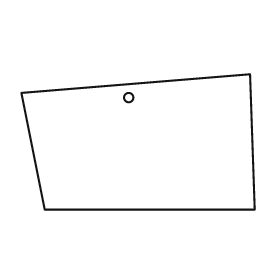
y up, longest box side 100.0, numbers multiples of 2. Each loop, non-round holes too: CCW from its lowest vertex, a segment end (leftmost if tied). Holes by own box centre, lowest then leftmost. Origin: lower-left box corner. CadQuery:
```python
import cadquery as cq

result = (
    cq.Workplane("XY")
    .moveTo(10.0, 0.0)
    .lineTo(100.0, 0.0)
    .lineTo(98.0, 58.0)
    .lineTo(0.0, 50.0)
    .close()
    .moveTo(46.0, 48.0)
    .circle(2.0)
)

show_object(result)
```